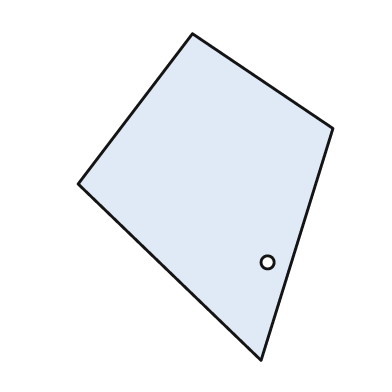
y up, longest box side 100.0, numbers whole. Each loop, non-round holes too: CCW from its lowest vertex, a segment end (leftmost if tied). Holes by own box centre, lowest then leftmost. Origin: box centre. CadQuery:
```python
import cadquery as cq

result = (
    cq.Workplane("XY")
    .moveTo(17.0, -50.0)
    .lineTo(39.0, 21.0)
    .lineTo(-4.0, 50.0)
    .lineTo(-39.0, 4.0)
    .close()
    .moveTo(19.0, -20.0)
    .circle(2.0)
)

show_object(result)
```